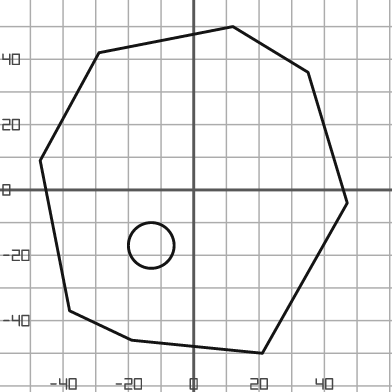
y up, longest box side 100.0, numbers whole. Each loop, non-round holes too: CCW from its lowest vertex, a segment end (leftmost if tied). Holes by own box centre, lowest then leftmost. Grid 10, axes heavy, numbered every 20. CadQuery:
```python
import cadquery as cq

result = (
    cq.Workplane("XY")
    .moveTo(21.0, -50.0)
    .lineTo(47.0, -4.0)
    .lineTo(35.0, 36.0)
    .lineTo(12.0, 50.0)
    .lineTo(-29.0, 42.0)
    .lineTo(-47.0, 9.0)
    .lineTo(-38.0, -37.0)
    .lineTo(-19.0, -46.0)
    .close()
    .moveTo(-13.0, -17.0)
    .circle(7.0)
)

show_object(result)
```